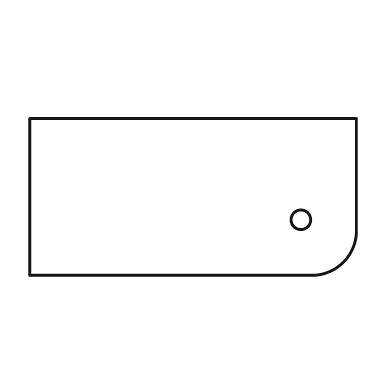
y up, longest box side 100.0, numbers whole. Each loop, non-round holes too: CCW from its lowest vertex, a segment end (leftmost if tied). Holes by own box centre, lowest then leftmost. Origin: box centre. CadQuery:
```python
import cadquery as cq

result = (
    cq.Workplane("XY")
    .moveTo(-50.0, -24.0)
    .lineTo(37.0, -24.0)
    .threePointArc((46.0, -20.0), (50.0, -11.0))
    .lineTo(50.0, 24.0)
    .lineTo(-50.0, 24.0)
    .close()
    .moveTo(33.0, -7.0)
    .circle(3.0)
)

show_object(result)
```